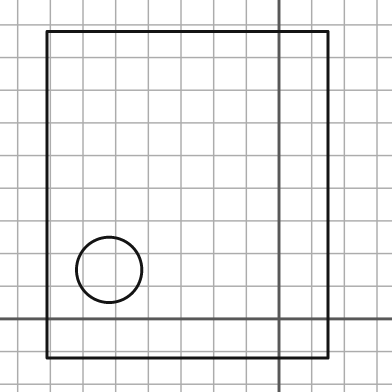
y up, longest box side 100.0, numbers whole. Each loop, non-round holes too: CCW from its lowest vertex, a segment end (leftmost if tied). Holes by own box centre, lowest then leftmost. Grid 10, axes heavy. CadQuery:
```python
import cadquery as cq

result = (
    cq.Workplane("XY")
    .moveTo(-71.0, -12.0)
    .lineTo(15.0, -12.0)
    .lineTo(15.0, 88.0)
    .lineTo(-71.0, 88.0)
    .close()
    .moveTo(-52.0, 15.0)
    .circle(10.0)
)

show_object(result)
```